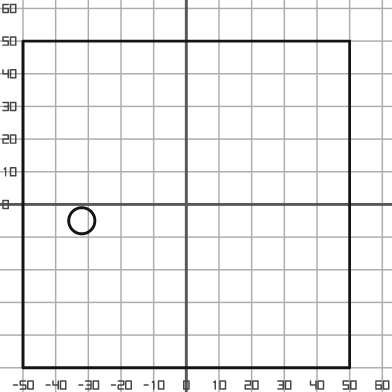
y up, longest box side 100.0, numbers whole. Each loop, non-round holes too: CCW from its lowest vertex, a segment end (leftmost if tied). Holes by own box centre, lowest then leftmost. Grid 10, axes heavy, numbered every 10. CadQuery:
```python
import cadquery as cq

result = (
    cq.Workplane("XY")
    .moveTo(-50.0, -50.0)
    .lineTo(50.0, -50.0)
    .lineTo(50.0, 50.0)
    .lineTo(-50.0, 50.0)
    .close()
    .moveTo(-32.0, -5.0)
    .circle(4.0)
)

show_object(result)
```